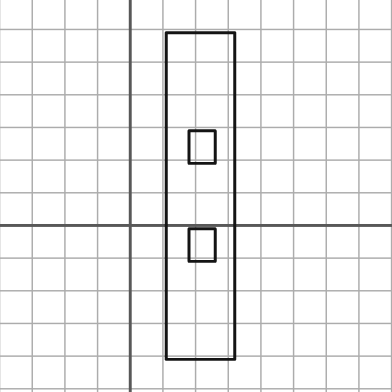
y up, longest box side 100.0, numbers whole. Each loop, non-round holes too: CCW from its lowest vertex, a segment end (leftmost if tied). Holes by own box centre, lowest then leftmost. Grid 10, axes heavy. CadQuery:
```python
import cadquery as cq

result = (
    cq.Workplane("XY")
    .moveTo(11.0, -41.0)
    .lineTo(32.0, -41.0)
    .lineTo(32.0, 59.0)
    .lineTo(11.0, 59.0)
    .close()
    .moveTo(18.0, -11.0)
    .lineTo(26.0, -11.0)
    .lineTo(26.0, -1.0)
    .lineTo(18.0, -1.0)
    .close()
    .moveTo(18.0, 19.0)
    .lineTo(26.0, 19.0)
    .lineTo(26.0, 29.0)
    .lineTo(18.0, 29.0)
    .close()
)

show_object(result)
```